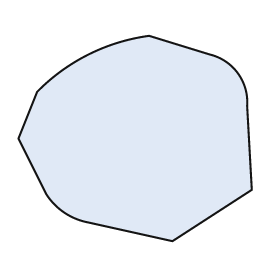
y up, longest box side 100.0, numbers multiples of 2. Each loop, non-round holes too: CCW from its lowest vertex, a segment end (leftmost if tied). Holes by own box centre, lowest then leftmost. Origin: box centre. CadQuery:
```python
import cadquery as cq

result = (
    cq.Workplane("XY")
    .moveTo(16.0, -44.0)
    .lineTo(50.0, -22.0)
    .lineTo(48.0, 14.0)
    .threePointArc((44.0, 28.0), (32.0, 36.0))
    .lineTo(6.0, 44.0)
    .threePointArc((-20.0, 36.0), (-42.0, 20.0))
    .lineTo(-50.0, 0.0)
    .lineTo(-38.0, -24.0)
    .threePointArc((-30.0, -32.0), (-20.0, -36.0))
    .close()
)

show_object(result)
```